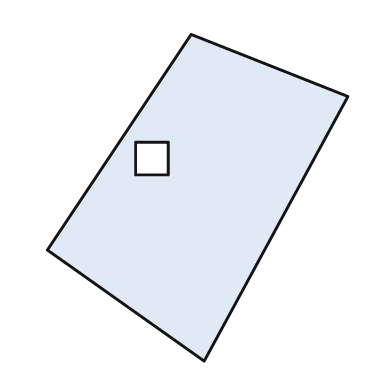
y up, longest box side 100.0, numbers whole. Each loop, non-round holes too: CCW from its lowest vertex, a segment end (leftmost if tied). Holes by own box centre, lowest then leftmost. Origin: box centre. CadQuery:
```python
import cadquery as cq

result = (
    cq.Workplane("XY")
    .moveTo(2.0, -50.0)
    .lineTo(46.0, 31.0)
    .lineTo(-2.0, 50.0)
    .lineTo(-46.0, -16.0)
    .close()
    .moveTo(-19.0, 7.0)
    .lineTo(-9.0, 7.0)
    .lineTo(-9.0, 17.0)
    .lineTo(-19.0, 17.0)
    .close()
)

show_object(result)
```